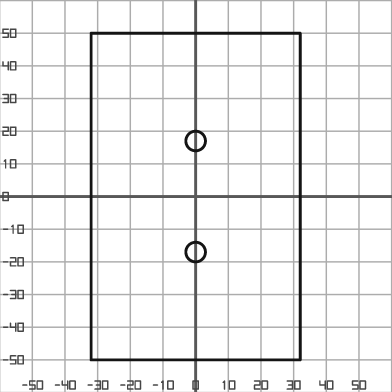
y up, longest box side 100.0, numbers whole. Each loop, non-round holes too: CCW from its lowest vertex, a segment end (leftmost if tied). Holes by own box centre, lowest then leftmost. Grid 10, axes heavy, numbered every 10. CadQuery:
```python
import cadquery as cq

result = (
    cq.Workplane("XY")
    .moveTo(-32.0, -50.0)
    .lineTo(32.0, -50.0)
    .lineTo(32.0, 50.0)
    .lineTo(-32.0, 50.0)
    .close()
    .moveTo(0.0, -17.0)
    .circle(3.0)
    .moveTo(0.0, 17.0)
    .circle(3.0)
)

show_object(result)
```